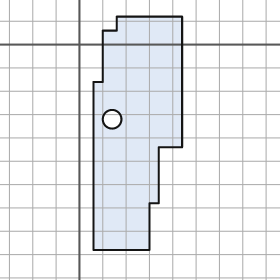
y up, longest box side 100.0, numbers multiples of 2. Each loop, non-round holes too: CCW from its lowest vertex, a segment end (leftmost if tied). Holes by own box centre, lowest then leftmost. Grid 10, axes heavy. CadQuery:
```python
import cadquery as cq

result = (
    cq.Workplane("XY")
    .moveTo(6.0, -88.0)
    .lineTo(30.0, -88.0)
    .lineTo(30.0, -68.0)
    .lineTo(34.0, -68.0)
    .lineTo(34.0, -44.0)
    .lineTo(44.0, -44.0)
    .lineTo(44.0, 12.0)
    .lineTo(16.0, 12.0)
    .lineTo(16.0, 6.0)
    .lineTo(10.0, 6.0)
    .lineTo(10.0, -16.0)
    .lineTo(6.0, -16.0)
    .close()
    .moveTo(14.0, -32.0)
    .circle(4.0)
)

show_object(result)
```